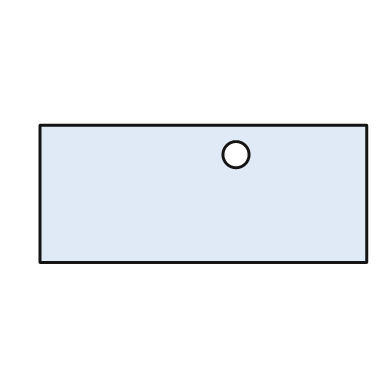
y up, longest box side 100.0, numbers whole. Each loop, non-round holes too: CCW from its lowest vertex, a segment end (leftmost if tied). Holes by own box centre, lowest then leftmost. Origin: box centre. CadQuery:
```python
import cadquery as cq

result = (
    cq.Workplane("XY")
    .moveTo(-50.0, -21.0)
    .lineTo(50.0, -21.0)
    .lineTo(50.0, 21.0)
    .lineTo(-50.0, 21.0)
    .close()
    .moveTo(10.0, 12.0)
    .circle(4.0)
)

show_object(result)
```